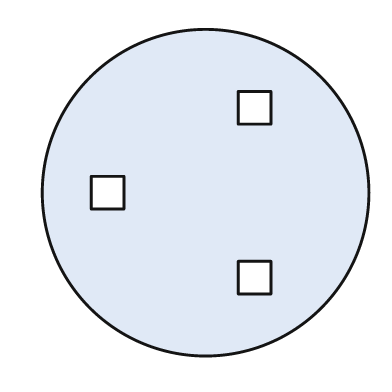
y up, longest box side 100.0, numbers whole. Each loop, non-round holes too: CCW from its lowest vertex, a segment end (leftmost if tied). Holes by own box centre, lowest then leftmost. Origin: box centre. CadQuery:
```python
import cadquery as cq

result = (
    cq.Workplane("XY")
    .moveTo(0.0, 0.0)
    .circle(50.0)
    .moveTo(10.0, -31.0)
    .lineTo(20.0, -31.0)
    .lineTo(20.0, -21.0)
    .lineTo(10.0, -21.0)
    .close()
    .moveTo(-35.0, -5.0)
    .lineTo(-25.0, -5.0)
    .lineTo(-25.0, 5.0)
    .lineTo(-35.0, 5.0)
    .close()
    .moveTo(10.0, 21.0)
    .lineTo(20.0, 21.0)
    .lineTo(20.0, 31.0)
    .lineTo(10.0, 31.0)
    .close()
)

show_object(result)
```